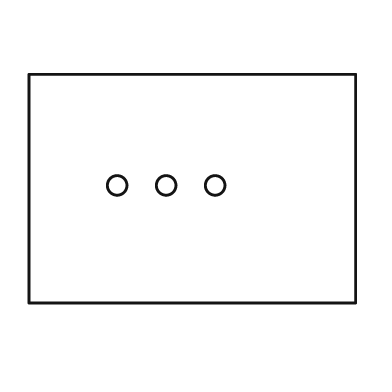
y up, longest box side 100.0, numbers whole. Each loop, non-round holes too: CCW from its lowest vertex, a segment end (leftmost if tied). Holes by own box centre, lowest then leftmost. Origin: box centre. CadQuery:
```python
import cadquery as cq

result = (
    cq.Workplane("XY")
    .moveTo(-50.0, -35.0)
    .lineTo(50.0, -35.0)
    .lineTo(50.0, 35.0)
    .lineTo(-50.0, 35.0)
    .close()
    .moveTo(-23.0, 1.0)
    .circle(3.0)
    .moveTo(-8.0, 1.0)
    .circle(3.0)
    .moveTo(7.0, 1.0)
    .circle(3.0)
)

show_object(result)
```